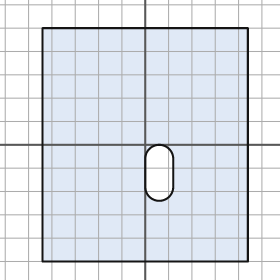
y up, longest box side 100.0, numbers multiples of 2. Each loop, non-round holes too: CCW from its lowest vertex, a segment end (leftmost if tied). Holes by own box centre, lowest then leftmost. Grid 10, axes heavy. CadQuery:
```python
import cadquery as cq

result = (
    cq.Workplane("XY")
    .moveTo(-44.0, -50.0)
    .lineTo(44.0, -50.0)
    .lineTo(44.0, 50.0)
    .lineTo(-44.0, 50.0)
    .close()
    .moveTo(0.0, -18.0)
    .threePointArc((6.0, -24.0), (12.0, -18.0))
    .lineTo(12.0, -6.0)
    .threePointArc((6.0, 0.0), (0.0, -6.0))
    .close()
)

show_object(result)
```